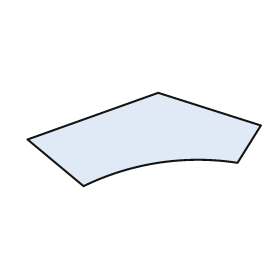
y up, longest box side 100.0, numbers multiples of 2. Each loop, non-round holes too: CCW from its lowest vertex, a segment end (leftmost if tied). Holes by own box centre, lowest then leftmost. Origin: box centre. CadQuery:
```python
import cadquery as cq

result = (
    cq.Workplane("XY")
    .moveTo(-26.0, -20.0)
    .threePointArc((6.0, -10.0), (40.0, -10.0))
    .lineTo(50.0, 6.0)
    .lineTo(6.0, 20.0)
    .lineTo(-50.0, 0.0)
    .close()
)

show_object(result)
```